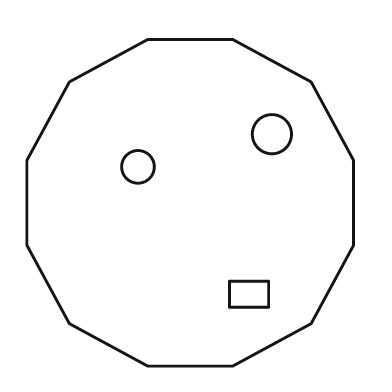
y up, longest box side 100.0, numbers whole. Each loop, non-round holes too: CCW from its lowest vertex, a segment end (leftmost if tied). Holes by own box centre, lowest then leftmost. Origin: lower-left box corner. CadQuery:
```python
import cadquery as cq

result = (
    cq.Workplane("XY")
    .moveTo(37.0, 0.0)
    .lineTo(63.0, 0.0)
    .lineTo(87.0, 13.0)
    .lineTo(100.0, 37.0)
    .lineTo(100.0, 63.0)
    .lineTo(87.0, 87.0)
    .lineTo(63.0, 100.0)
    .lineTo(37.0, 100.0)
    .lineTo(13.0, 87.0)
    .lineTo(0.0, 63.0)
    .lineTo(0.0, 37.0)
    .lineTo(13.0, 13.0)
    .close()
    .moveTo(62.0, 18.0)
    .lineTo(74.0, 18.0)
    .lineTo(74.0, 26.0)
    .lineTo(62.0, 26.0)
    .close()
    .moveTo(34.0, 61.0)
    .circle(5.0)
    .moveTo(75.0, 71.0)
    .circle(6.0)
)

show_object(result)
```